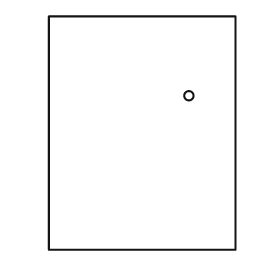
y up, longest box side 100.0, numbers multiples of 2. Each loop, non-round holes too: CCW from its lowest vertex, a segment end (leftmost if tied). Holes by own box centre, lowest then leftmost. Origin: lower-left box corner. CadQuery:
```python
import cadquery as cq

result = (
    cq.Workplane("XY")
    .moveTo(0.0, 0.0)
    .lineTo(80.0, 0.0)
    .lineTo(80.0, 100.0)
    .lineTo(0.0, 100.0)
    .close()
    .moveTo(60.0, 66.0)
    .circle(2.0)
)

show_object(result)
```